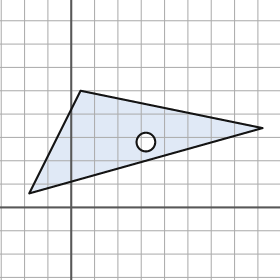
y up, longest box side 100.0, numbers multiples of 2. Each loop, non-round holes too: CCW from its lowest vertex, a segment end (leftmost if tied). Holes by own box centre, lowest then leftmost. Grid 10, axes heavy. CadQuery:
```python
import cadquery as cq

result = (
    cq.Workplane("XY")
    .moveTo(-18.0, 6.0)
    .lineTo(82.0, 34.0)
    .lineTo(4.0, 50.0)
    .close()
    .moveTo(32.0, 28.0)
    .circle(4.0)
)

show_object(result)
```